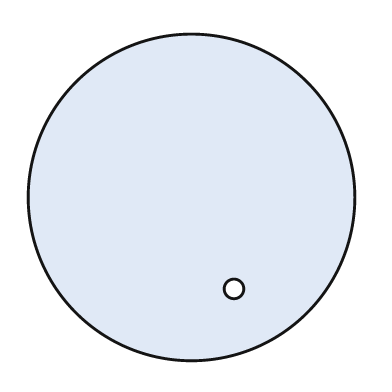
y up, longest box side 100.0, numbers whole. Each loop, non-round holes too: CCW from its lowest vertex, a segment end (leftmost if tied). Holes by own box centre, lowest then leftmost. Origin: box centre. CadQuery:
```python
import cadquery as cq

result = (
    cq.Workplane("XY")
    .moveTo(0.0, 0.0)
    .circle(50.0)
    .moveTo(13.0, -28.0)
    .circle(3.0)
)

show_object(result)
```